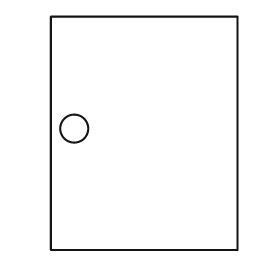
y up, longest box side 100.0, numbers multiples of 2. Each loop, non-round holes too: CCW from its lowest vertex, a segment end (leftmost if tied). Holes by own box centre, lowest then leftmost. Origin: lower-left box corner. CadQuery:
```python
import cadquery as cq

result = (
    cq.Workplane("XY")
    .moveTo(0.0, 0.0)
    .lineTo(80.0, 0.0)
    .lineTo(80.0, 100.0)
    .lineTo(0.0, 100.0)
    .close()
    .moveTo(10.0, 52.0)
    .circle(6.0)
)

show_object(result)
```